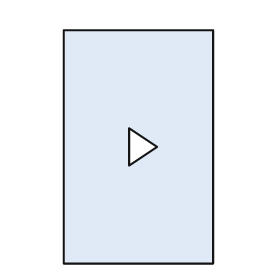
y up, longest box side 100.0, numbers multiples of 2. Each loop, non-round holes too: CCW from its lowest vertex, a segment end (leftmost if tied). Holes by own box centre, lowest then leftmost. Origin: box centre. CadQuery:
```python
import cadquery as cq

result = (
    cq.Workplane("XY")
    .moveTo(-32.0, -50.0)
    .lineTo(32.0, -50.0)
    .lineTo(32.0, 50.0)
    .lineTo(-32.0, 50.0)
    .close()
    .moveTo(-4.0, -8.0)
    .lineTo(8.0, 0.0)
    .lineTo(-4.0, 8.0)
    .close()
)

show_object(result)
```